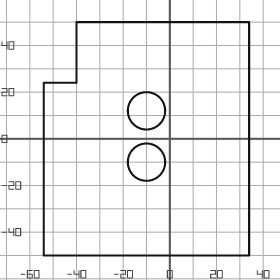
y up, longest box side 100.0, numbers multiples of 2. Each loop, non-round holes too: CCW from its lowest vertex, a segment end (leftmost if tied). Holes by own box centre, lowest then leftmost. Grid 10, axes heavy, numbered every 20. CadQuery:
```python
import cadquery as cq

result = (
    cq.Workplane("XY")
    .moveTo(-54.0, -50.0)
    .lineTo(34.0, -50.0)
    .lineTo(34.0, 50.0)
    .lineTo(-40.0, 50.0)
    .lineTo(-40.0, 24.0)
    .lineTo(-54.0, 24.0)
    .close()
    .moveTo(-10.0, -10.0)
    .circle(8.0)
    .moveTo(-10.0, 12.0)
    .circle(8.0)
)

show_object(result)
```